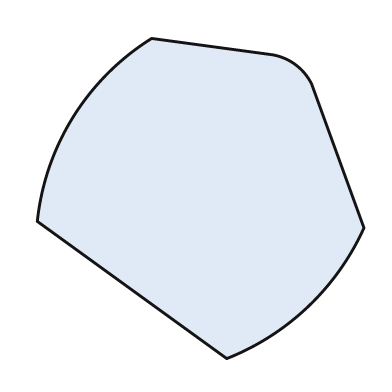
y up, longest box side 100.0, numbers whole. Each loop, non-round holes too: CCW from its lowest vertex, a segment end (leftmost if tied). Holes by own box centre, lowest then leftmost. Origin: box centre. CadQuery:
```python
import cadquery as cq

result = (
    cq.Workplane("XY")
    .moveTo(8.0, -49.0)
    .threePointArc((33.0, -33.0), (50.0, -9.0))
    .lineTo(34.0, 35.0)
    .threePointArc((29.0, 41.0), (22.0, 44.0))
    .lineTo(-15.0, 49.0)
    .threePointArc((-39.0, 25.0), (-50.0, -7.0))
    .close()
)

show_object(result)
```